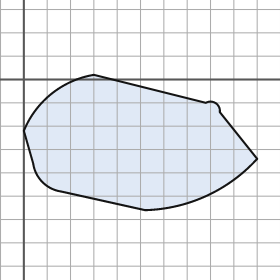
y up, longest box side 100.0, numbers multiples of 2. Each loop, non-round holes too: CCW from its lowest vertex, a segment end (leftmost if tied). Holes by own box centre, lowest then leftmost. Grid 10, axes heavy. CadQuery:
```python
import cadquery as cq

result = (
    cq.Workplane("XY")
    .moveTo(52.0, -56.0)
    .threePointArc((78.0, -50.0), (100.0, -34.0))
    .lineTo(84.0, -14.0)
    .threePointArc((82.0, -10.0), (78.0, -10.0))
    .lineTo(30.0, 2.0)
    .threePointArc((12.0, -6.0), (0.0, -22.0))
    .lineTo(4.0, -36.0)
    .threePointArc((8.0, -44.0), (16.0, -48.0))
    .close()
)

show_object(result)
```